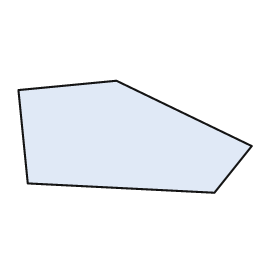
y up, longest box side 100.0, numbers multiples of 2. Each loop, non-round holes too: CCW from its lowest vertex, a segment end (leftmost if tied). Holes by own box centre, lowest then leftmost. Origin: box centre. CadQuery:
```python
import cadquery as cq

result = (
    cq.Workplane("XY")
    .moveTo(34.0, -24.0)
    .lineTo(50.0, -4.0)
    .lineTo(-8.0, 24.0)
    .lineTo(-50.0, 20.0)
    .lineTo(-46.0, -20.0)
    .close()
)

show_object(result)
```